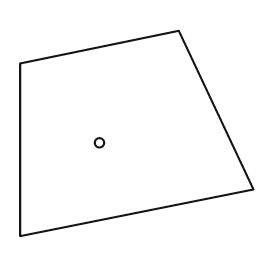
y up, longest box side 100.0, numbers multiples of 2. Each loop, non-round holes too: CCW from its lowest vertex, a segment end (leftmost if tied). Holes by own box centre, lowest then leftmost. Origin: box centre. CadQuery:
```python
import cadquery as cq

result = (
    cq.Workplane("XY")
    .moveTo(-50.0, -44.0)
    .lineTo(50.0, -24.0)
    .lineTo(18.0, 44.0)
    .lineTo(-50.0, 30.0)
    .close()
    .moveTo(-16.0, -4.0)
    .circle(2.0)
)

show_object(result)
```